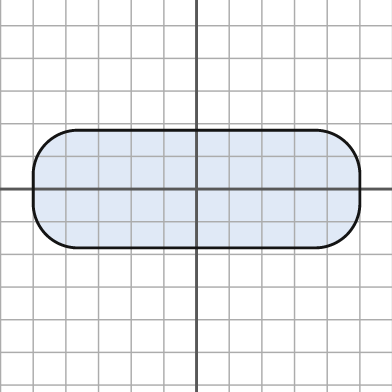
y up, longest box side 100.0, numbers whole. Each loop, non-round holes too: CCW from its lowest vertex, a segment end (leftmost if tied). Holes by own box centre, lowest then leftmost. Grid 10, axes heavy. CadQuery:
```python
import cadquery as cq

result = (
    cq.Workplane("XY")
    .moveTo(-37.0, -18.0)
    .lineTo(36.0, -18.0)
    .threePointArc((46.0, -14.0), (50.0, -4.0))
    .lineTo(50.0, 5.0)
    .threePointArc((46.0, 14.0), (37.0, 18.0))
    .lineTo(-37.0, 18.0)
    .threePointArc((-46.0, 14.0), (-50.0, 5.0))
    .lineTo(-50.0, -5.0)
    .threePointArc((-46.0, -14.0), (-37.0, -18.0))
    .close()
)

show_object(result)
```